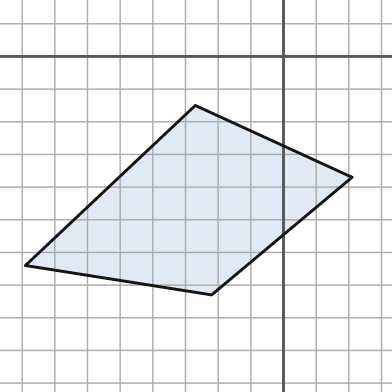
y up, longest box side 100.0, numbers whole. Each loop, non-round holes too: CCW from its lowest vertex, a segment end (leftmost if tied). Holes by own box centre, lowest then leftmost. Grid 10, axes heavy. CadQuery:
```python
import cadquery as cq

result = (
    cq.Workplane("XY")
    .moveTo(-22.0, -73.0)
    .lineTo(21.0, -37.0)
    .lineTo(-27.0, -15.0)
    .lineTo(-79.0, -64.0)
    .close()
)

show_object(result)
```